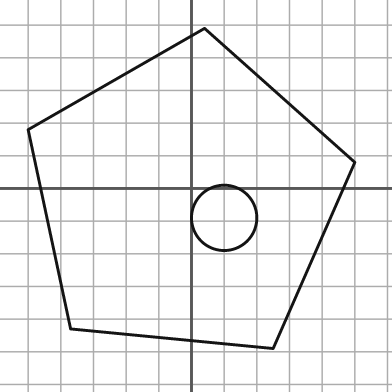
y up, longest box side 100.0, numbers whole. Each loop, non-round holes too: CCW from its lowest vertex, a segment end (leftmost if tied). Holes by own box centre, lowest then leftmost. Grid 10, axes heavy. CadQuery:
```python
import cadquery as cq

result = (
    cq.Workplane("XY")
    .moveTo(25.0, -49.0)
    .lineTo(50.0, 8.0)
    .lineTo(4.0, 49.0)
    .lineTo(-50.0, 18.0)
    .lineTo(-37.0, -43.0)
    .close()
    .moveTo(10.0, -9.0)
    .circle(10.0)
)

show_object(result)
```